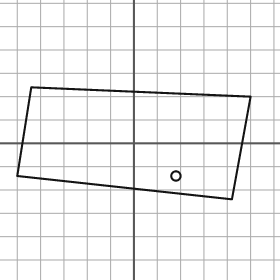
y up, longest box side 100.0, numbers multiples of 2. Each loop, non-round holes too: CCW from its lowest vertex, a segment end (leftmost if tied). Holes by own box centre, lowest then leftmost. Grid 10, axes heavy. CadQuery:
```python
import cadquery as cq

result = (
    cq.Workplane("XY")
    .moveTo(42.0, -24.0)
    .lineTo(50.0, 20.0)
    .lineTo(-44.0, 24.0)
    .lineTo(-50.0, -14.0)
    .close()
    .moveTo(18.0, -14.0)
    .circle(2.0)
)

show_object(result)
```